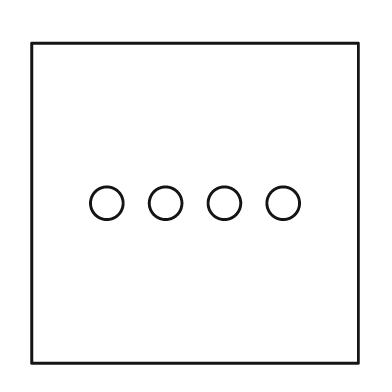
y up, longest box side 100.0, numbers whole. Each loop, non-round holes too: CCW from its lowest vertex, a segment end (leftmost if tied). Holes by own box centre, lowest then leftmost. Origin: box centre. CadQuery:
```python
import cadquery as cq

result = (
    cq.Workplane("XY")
    .moveTo(-50.0, -49.0)
    .lineTo(50.0, -49.0)
    .lineTo(50.0, 49.0)
    .lineTo(-50.0, 49.0)
    .close()
    .moveTo(-27.0, 0.0)
    .circle(5.0)
    .moveTo(-9.0, 0.0)
    .circle(5.0)
    .moveTo(9.0, 0.0)
    .circle(5.0)
    .moveTo(27.0, 0.0)
    .circle(5.0)
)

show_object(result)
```